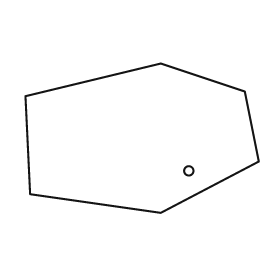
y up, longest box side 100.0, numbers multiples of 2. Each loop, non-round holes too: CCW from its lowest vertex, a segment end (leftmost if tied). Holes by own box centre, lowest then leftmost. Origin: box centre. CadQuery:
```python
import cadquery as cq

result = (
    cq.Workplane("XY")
    .moveTo(8.0, -32.0)
    .lineTo(50.0, -10.0)
    .lineTo(44.0, 20.0)
    .lineTo(8.0, 32.0)
    .lineTo(-50.0, 18.0)
    .lineTo(-48.0, -24.0)
    .close()
    .moveTo(20.0, -14.0)
    .circle(2.0)
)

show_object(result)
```